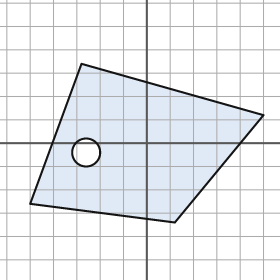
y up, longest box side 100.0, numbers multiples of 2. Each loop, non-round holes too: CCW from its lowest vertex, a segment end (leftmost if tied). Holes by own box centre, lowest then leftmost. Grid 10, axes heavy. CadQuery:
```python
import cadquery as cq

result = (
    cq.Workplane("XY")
    .moveTo(12.0, -34.0)
    .lineTo(50.0, 12.0)
    .lineTo(-28.0, 34.0)
    .lineTo(-50.0, -26.0)
    .close()
    .moveTo(-26.0, -4.0)
    .circle(6.0)
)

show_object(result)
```